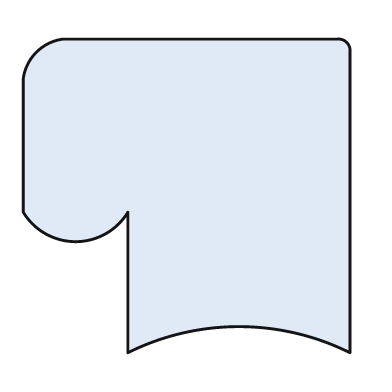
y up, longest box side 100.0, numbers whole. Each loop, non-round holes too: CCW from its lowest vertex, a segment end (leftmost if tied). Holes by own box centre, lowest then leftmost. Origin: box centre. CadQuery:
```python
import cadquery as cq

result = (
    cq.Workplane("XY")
    .moveTo(-18.0, -48.0)
    .threePointArc((16.0, -40.0), (50.0, -48.0))
    .lineTo(50.0, 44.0)
    .threePointArc((49.0, 47.0), (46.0, 48.0))
    .lineTo(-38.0, 48.0)
    .threePointArc((-46.0, 44.0), (-50.0, 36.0))
    .lineTo(-50.0, -5.0)
    .threePointArc((-34.0, -14.0), (-18.0, -5.0))
    .close()
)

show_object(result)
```